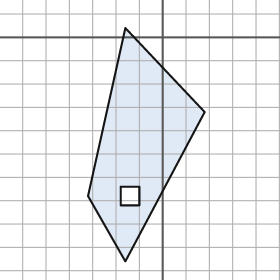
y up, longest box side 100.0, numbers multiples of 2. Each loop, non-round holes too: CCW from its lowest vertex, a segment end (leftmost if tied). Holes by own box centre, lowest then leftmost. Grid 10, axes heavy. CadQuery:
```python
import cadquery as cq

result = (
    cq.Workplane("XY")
    .moveTo(-16.0, -96.0)
    .lineTo(18.0, -32.0)
    .lineTo(-16.0, 4.0)
    .lineTo(-32.0, -68.0)
    .close()
    .moveTo(-18.0, -72.0)
    .lineTo(-10.0, -72.0)
    .lineTo(-10.0, -64.0)
    .lineTo(-18.0, -64.0)
    .close()
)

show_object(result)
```